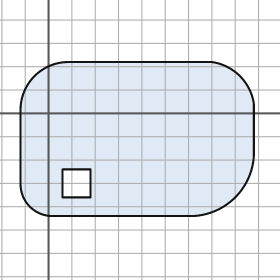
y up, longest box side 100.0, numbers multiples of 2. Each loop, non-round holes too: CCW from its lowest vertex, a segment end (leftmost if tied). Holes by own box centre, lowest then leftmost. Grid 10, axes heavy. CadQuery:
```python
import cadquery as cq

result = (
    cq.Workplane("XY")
    .moveTo(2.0, -44.0)
    .lineTo(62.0, -44.0)
    .threePointArc((80.0, -36.0), (88.0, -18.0))
    .lineTo(88.0, 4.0)
    .threePointArc((82.0, 16.0), (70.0, 22.0))
    .lineTo(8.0, 22.0)
    .threePointArc((-6.0, 16.0), (-12.0, 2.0))
    .lineTo(-12.0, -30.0)
    .threePointArc((-8.0, -40.0), (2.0, -44.0))
    .close()
    .moveTo(6.0, -36.0)
    .lineTo(18.0, -36.0)
    .lineTo(18.0, -24.0)
    .lineTo(6.0, -24.0)
    .close()
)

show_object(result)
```